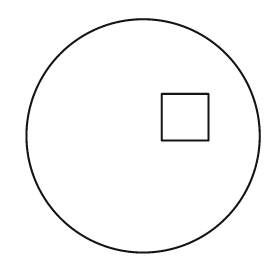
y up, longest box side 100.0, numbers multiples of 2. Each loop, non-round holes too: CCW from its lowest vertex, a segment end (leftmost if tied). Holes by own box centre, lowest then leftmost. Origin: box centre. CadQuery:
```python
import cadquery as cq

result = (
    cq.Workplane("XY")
    .moveTo(0.0, 0.0)
    .circle(50.0)
    .moveTo(8.0, -2.0)
    .lineTo(28.0, -2.0)
    .lineTo(28.0, 18.0)
    .lineTo(8.0, 18.0)
    .close()
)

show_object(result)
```